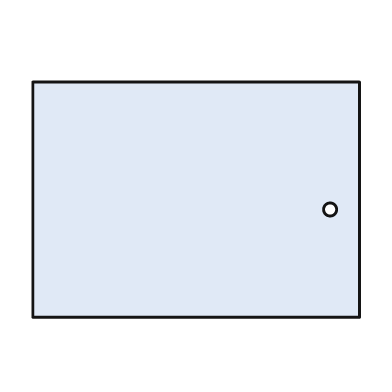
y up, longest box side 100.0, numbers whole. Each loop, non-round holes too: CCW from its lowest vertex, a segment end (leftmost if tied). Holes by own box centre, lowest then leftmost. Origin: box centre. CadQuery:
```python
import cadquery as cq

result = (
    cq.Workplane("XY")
    .moveTo(-50.0, -36.0)
    .lineTo(50.0, -36.0)
    .lineTo(50.0, 36.0)
    .lineTo(-50.0, 36.0)
    .close()
    .moveTo(41.0, -3.0)
    .circle(2.0)
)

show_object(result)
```